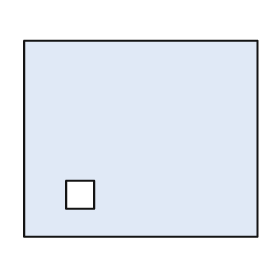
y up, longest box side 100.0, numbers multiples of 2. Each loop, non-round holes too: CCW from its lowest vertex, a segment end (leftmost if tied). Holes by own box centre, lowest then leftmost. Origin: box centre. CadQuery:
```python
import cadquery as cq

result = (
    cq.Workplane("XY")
    .moveTo(-50.0, -42.0)
    .lineTo(50.0, -42.0)
    .lineTo(50.0, 42.0)
    .lineTo(-50.0, 42.0)
    .close()
    .moveTo(-32.0, -30.0)
    .lineTo(-20.0, -30.0)
    .lineTo(-20.0, -18.0)
    .lineTo(-32.0, -18.0)
    .close()
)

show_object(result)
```